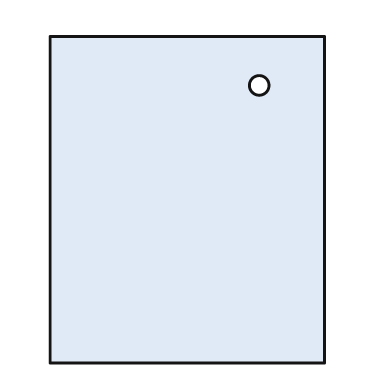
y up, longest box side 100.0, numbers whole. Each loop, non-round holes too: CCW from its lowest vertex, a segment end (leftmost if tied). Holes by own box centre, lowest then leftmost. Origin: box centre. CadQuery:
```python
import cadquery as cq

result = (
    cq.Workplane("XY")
    .moveTo(-42.0, -50.0)
    .lineTo(42.0, -50.0)
    .lineTo(42.0, 50.0)
    .lineTo(-42.0, 50.0)
    .close()
    .moveTo(22.0, 35.0)
    .circle(3.0)
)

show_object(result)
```